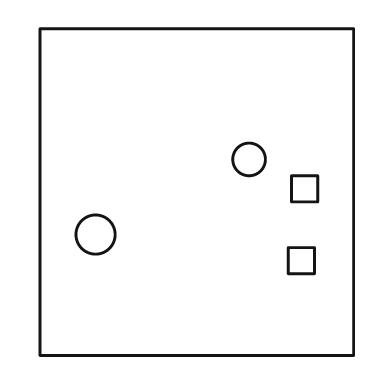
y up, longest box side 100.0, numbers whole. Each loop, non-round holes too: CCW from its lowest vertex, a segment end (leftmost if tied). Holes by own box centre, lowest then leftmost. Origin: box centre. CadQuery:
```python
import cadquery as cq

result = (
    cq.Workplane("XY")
    .moveTo(-48.0, -50.0)
    .lineTo(48.0, -50.0)
    .lineTo(48.0, 50.0)
    .lineTo(-48.0, 50.0)
    .close()
    .moveTo(28.0, -25.0)
    .lineTo(36.0, -25.0)
    .lineTo(36.0, -17.0)
    .lineTo(28.0, -17.0)
    .close()
    .moveTo(-31.0, -13.0)
    .circle(6.0)
    .moveTo(29.0, -3.0)
    .lineTo(37.0, -3.0)
    .lineTo(37.0, 5.0)
    .lineTo(29.0, 5.0)
    .close()
    .moveTo(16.0, 10.0)
    .circle(5.0)
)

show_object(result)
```